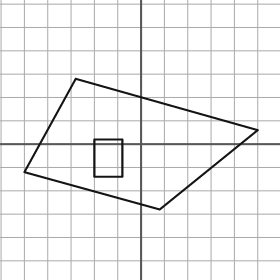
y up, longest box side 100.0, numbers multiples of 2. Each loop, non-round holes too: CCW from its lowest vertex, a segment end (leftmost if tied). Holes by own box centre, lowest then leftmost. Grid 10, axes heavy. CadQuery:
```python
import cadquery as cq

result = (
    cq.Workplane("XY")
    .moveTo(8.0, -28.0)
    .lineTo(50.0, 6.0)
    .lineTo(-28.0, 28.0)
    .lineTo(-50.0, -12.0)
    .close()
    .moveTo(-20.0, -14.0)
    .lineTo(-8.0, -14.0)
    .lineTo(-8.0, 2.0)
    .lineTo(-20.0, 2.0)
    .close()
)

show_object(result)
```